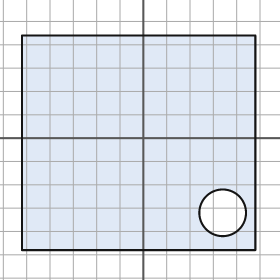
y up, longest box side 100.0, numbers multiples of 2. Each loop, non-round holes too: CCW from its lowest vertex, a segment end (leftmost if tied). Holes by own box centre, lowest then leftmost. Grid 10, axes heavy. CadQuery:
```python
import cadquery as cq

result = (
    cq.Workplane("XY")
    .moveTo(-52.0, -48.0)
    .lineTo(48.0, -48.0)
    .lineTo(48.0, 44.0)
    .lineTo(-52.0, 44.0)
    .close()
    .moveTo(34.0, -32.0)
    .circle(10.0)
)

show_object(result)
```